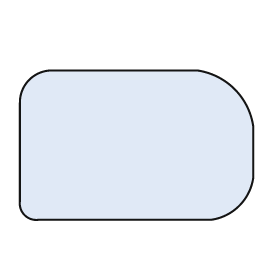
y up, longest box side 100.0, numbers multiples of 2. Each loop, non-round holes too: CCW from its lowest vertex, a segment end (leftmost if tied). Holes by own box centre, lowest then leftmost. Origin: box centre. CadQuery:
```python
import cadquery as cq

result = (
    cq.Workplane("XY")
    .moveTo(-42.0, -32.0)
    .lineTo(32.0, -32.0)
    .threePointArc((44.0, -26.0), (50.0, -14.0))
    .lineTo(50.0, 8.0)
    .threePointArc((42.0, 24.0), (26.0, 32.0))
    .lineTo(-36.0, 32.0)
    .threePointArc((-46.0, 28.0), (-50.0, 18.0))
    .lineTo(-50.0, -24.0)
    .threePointArc((-48.0, -30.0), (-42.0, -32.0))
    .close()
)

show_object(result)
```